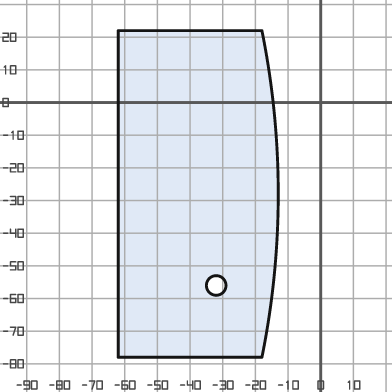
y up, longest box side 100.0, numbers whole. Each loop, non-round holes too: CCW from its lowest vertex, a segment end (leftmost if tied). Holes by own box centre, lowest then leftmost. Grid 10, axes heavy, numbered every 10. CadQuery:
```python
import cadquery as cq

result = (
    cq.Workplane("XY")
    .moveTo(-62.0, -78.0)
    .lineTo(-18.0, -78.0)
    .threePointArc((-13.0, -28.0), (-18.0, 22.0))
    .lineTo(-62.0, 22.0)
    .close()
    .moveTo(-32.0, -56.0)
    .circle(3.0)
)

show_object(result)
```